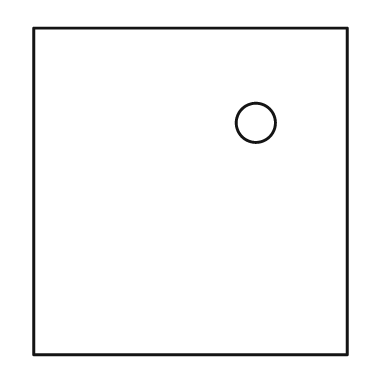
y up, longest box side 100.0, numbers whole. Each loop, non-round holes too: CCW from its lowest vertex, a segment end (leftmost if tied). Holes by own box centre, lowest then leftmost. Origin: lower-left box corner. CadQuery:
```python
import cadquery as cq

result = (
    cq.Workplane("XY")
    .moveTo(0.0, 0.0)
    .lineTo(96.0, 0.0)
    .lineTo(96.0, 100.0)
    .lineTo(0.0, 100.0)
    .close()
    .moveTo(68.0, 71.0)
    .circle(6.0)
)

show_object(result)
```